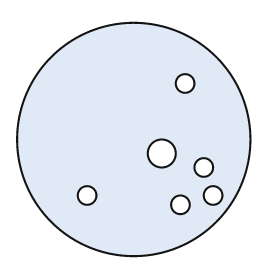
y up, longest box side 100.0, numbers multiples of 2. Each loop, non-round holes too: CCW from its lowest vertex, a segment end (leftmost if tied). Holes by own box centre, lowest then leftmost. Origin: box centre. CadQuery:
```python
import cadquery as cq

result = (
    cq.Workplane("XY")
    .moveTo(0.0, 0.0)
    .circle(50.0)
    .moveTo(20.0, -28.0)
    .circle(4.0)
    .moveTo(-20.0, -24.0)
    .circle(4.0)
    .moveTo(34.0, -24.0)
    .circle(4.0)
    .moveTo(30.0, -12.0)
    .circle(4.0)
    .moveTo(12.0, -6.0)
    .circle(6.0)
    .moveTo(22.0, 24.0)
    .circle(4.0)
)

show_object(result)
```